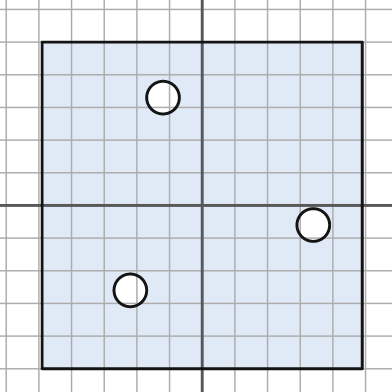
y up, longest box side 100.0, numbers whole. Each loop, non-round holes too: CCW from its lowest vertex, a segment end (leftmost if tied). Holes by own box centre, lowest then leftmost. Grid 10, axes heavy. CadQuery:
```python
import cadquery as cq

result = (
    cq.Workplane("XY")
    .moveTo(-49.0, -50.0)
    .lineTo(49.0, -50.0)
    .lineTo(49.0, 50.0)
    .lineTo(-49.0, 50.0)
    .close()
    .moveTo(-22.0, -26.0)
    .circle(5.0)
    .moveTo(34.0, -6.0)
    .circle(5.0)
    .moveTo(-12.0, 33.0)
    .circle(5.0)
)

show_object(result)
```